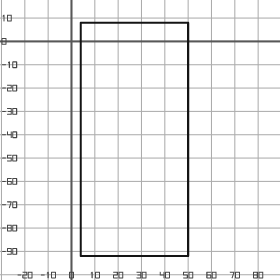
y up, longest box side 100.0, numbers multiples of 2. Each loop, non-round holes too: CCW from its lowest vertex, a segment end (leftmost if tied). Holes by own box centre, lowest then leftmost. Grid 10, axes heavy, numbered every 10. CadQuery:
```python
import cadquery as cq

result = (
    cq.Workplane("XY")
    .moveTo(4.0, -92.0)
    .lineTo(50.0, -92.0)
    .lineTo(50.0, 8.0)
    .lineTo(4.0, 8.0)
    .close()
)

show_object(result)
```